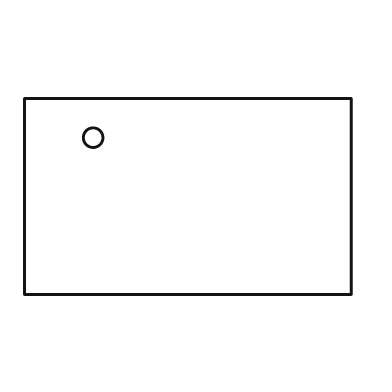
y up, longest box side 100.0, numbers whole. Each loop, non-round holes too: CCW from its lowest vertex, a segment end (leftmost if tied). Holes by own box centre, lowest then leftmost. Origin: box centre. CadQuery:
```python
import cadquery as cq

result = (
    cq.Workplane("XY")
    .moveTo(-50.0, -30.0)
    .lineTo(50.0, -30.0)
    .lineTo(50.0, 30.0)
    .lineTo(-50.0, 30.0)
    .close()
    .moveTo(-29.0, 18.0)
    .circle(3.0)
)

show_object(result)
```